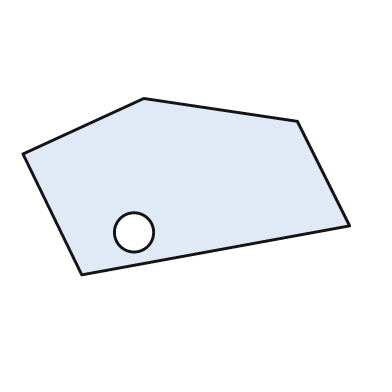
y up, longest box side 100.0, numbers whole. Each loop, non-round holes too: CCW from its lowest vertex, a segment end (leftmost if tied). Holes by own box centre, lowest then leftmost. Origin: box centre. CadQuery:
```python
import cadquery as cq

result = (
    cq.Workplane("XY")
    .moveTo(-32.0, -27.0)
    .lineTo(50.0, -12.0)
    .lineTo(34.0, 20.0)
    .lineTo(-13.0, 27.0)
    .lineTo(-50.0, 10.0)
    .close()
    .moveTo(-16.0, -14.0)
    .circle(6.0)
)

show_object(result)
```